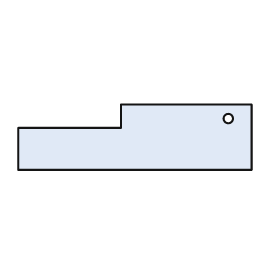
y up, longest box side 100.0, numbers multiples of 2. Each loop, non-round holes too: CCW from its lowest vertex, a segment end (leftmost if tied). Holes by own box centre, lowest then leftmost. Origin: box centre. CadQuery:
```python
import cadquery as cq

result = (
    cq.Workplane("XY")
    .moveTo(-50.0, -14.0)
    .lineTo(50.0, -14.0)
    .lineTo(50.0, 14.0)
    .lineTo(-6.0, 14.0)
    .lineTo(-6.0, 4.0)
    .lineTo(-50.0, 4.0)
    .close()
    .moveTo(40.0, 8.0)
    .circle(2.0)
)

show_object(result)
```